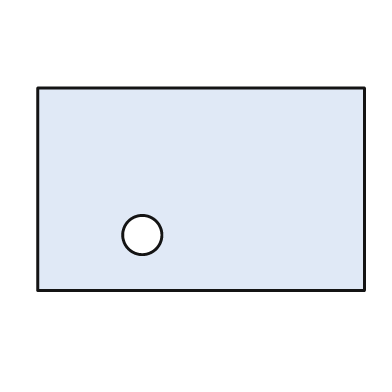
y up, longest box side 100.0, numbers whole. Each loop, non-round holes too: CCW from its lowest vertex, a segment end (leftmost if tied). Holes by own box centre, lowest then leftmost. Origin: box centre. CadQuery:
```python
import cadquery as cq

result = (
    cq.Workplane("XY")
    .moveTo(-50.0, -31.0)
    .lineTo(50.0, -31.0)
    .lineTo(50.0, 31.0)
    .lineTo(-50.0, 31.0)
    .close()
    .moveTo(-18.0, -14.0)
    .circle(6.0)
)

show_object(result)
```